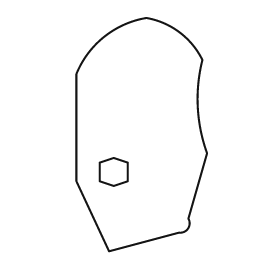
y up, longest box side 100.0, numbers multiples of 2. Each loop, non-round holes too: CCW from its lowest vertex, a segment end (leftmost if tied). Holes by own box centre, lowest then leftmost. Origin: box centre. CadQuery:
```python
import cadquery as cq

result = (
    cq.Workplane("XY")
    .moveTo(-14.0, -50.0)
    .lineTo(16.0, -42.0)
    .threePointArc((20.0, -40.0), (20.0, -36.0))
    .lineTo(28.0, -8.0)
    .threePointArc((24.0, 12.0), (26.0, 32.0))
    .threePointArc((16.0, 44.0), (2.0, 50.0))
    .threePointArc((-16.0, 42.0), (-28.0, 26.0))
    .lineTo(-28.0, -20.0)
    .close()
    .moveTo(-12.0, -22.0)
    .lineTo(-6.0, -20.0)
    .lineTo(-6.0, -12.0)
    .lineTo(-12.0, -10.0)
    .lineTo(-18.0, -12.0)
    .lineTo(-18.0, -20.0)
    .close()
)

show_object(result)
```